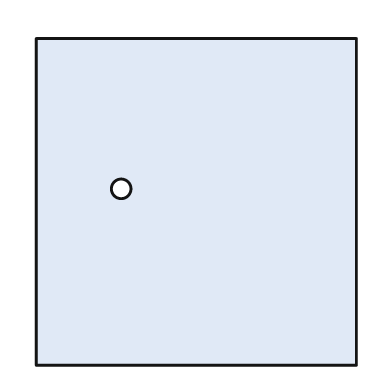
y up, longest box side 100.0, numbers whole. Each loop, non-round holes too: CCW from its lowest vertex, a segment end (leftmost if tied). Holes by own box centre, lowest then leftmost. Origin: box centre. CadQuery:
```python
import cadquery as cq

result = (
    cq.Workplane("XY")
    .moveTo(-49.0, -50.0)
    .lineTo(49.0, -50.0)
    .lineTo(49.0, 50.0)
    .lineTo(-49.0, 50.0)
    .close()
    .moveTo(-23.0, 4.0)
    .circle(3.0)
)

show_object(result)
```